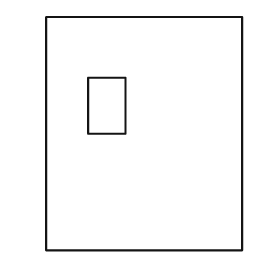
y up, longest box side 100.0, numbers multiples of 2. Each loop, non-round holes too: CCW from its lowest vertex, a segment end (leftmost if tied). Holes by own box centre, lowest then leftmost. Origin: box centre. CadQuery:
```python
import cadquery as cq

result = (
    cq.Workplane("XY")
    .moveTo(-42.0, -50.0)
    .lineTo(42.0, -50.0)
    .lineTo(42.0, 50.0)
    .lineTo(-42.0, 50.0)
    .close()
    .moveTo(-24.0, 0.0)
    .lineTo(-8.0, 0.0)
    .lineTo(-8.0, 24.0)
    .lineTo(-24.0, 24.0)
    .close()
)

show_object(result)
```